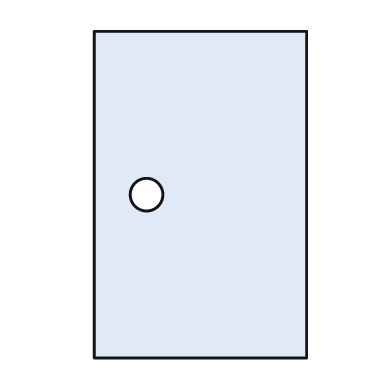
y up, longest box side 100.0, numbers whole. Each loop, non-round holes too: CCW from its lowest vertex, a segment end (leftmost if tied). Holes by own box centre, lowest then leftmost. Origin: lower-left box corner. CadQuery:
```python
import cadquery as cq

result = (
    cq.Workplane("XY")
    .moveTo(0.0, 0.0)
    .lineTo(65.0, 0.0)
    .lineTo(65.0, 100.0)
    .lineTo(0.0, 100.0)
    .close()
    .moveTo(16.0, 50.0)
    .circle(5.0)
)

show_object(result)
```